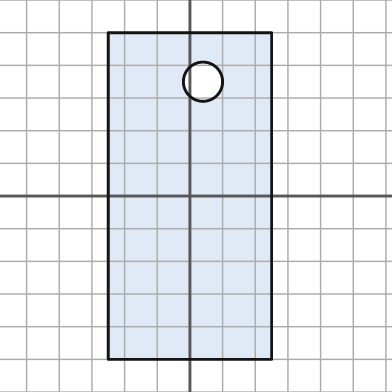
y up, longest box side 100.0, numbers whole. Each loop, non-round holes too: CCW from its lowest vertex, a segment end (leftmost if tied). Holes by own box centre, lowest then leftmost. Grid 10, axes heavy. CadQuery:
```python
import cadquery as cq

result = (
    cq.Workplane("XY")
    .moveTo(-25.0, -50.0)
    .lineTo(25.0, -50.0)
    .lineTo(25.0, 50.0)
    .lineTo(-25.0, 50.0)
    .close()
    .moveTo(4.0, 35.0)
    .circle(6.0)
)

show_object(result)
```